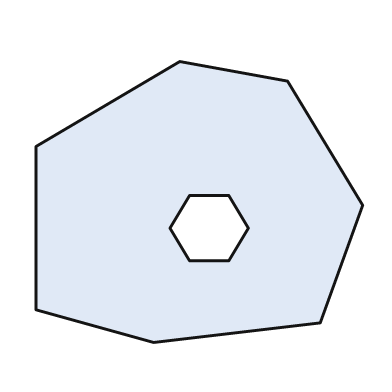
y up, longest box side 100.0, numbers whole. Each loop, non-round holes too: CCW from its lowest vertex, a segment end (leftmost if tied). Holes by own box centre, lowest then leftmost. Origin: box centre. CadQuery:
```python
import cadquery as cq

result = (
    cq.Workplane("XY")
    .moveTo(-14.0, -43.0)
    .lineTo(37.0, -37.0)
    .lineTo(50.0, -1.0)
    .lineTo(27.0, 37.0)
    .lineTo(-6.0, 43.0)
    .lineTo(-50.0, 17.0)
    .lineTo(-50.0, -33.0)
    .close()
    .moveTo(-3.0, -18.0)
    .lineTo(9.0, -18.0)
    .lineTo(15.0, -8.0)
    .lineTo(9.0, 2.0)
    .lineTo(-3.0, 2.0)
    .lineTo(-9.0, -8.0)
    .close()
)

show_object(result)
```